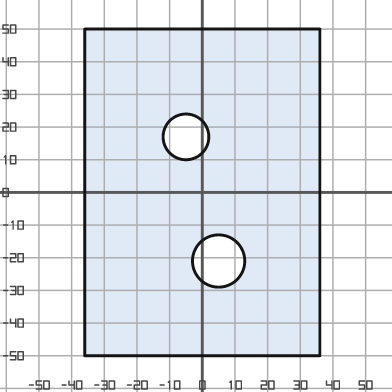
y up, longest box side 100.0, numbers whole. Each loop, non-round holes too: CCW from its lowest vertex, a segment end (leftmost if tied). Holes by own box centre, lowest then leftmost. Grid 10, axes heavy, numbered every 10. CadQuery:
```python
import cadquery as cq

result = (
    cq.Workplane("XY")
    .moveTo(-36.0, -50.0)
    .lineTo(36.0, -50.0)
    .lineTo(36.0, 50.0)
    .lineTo(-36.0, 50.0)
    .close()
    .moveTo(5.0, -21.0)
    .circle(8.0)
    .moveTo(-5.0, 17.0)
    .circle(7.0)
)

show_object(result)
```